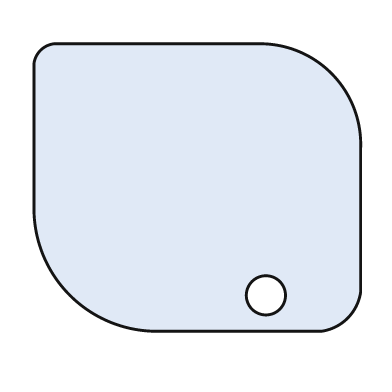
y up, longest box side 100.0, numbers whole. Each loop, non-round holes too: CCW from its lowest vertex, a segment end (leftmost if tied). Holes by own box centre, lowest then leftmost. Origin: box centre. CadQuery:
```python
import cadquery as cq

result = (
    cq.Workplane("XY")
    .moveTo(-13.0, -44.0)
    .lineTo(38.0, -44.0)
    .threePointArc((46.0, -40.0), (50.0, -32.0))
    .lineTo(50.0, 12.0)
    .threePointArc((41.0, 35.0), (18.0, 44.0))
    .lineTo(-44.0, 44.0)
    .threePointArc((-48.0, 42.0), (-50.0, 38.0))
    .lineTo(-50.0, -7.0)
    .threePointArc((-39.0, -33.0), (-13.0, -44.0))
    .close()
    .moveTo(21.0, -33.0)
    .circle(6.0)
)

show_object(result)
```